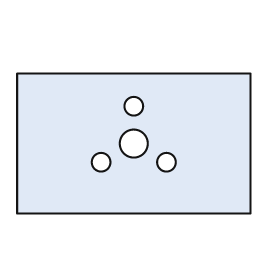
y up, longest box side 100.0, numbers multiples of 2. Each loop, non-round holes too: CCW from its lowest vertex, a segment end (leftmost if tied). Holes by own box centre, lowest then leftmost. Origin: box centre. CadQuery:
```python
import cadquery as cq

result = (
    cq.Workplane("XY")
    .moveTo(-50.0, -30.0)
    .lineTo(50.0, -30.0)
    .lineTo(50.0, 30.0)
    .lineTo(-50.0, 30.0)
    .close()
    .moveTo(-14.0, -8.0)
    .circle(4.0)
    .moveTo(14.0, -8.0)
    .circle(4.0)
    .moveTo(0.0, 0.0)
    .circle(6.0)
    .moveTo(0.0, 16.0)
    .circle(4.0)
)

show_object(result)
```